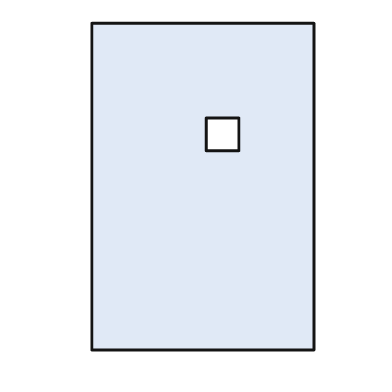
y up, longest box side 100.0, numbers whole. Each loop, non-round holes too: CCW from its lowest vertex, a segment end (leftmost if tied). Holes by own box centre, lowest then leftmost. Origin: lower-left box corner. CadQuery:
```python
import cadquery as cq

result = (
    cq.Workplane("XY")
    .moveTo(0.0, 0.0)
    .lineTo(68.0, 0.0)
    .lineTo(68.0, 100.0)
    .lineTo(0.0, 100.0)
    .close()
    .moveTo(35.0, 61.0)
    .lineTo(45.0, 61.0)
    .lineTo(45.0, 71.0)
    .lineTo(35.0, 71.0)
    .close()
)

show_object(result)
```